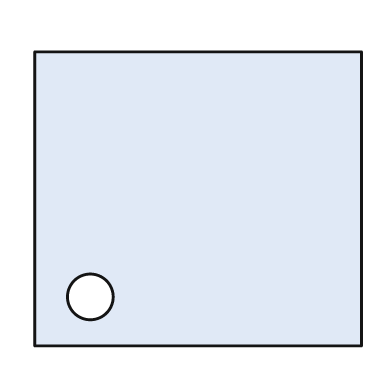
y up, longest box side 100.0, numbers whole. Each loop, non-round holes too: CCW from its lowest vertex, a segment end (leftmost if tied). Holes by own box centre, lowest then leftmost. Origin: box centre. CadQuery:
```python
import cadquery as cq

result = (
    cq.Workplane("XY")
    .moveTo(-50.0, -45.0)
    .lineTo(50.0, -45.0)
    .lineTo(50.0, 45.0)
    .lineTo(-50.0, 45.0)
    .close()
    .moveTo(-33.0, -30.0)
    .circle(7.0)
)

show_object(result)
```